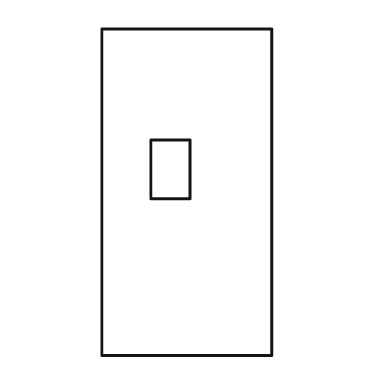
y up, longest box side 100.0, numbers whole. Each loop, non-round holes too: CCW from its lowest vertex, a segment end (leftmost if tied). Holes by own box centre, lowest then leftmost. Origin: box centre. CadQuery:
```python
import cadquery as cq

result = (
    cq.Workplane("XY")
    .moveTo(-26.0, -50.0)
    .lineTo(26.0, -50.0)
    .lineTo(26.0, 50.0)
    .lineTo(-26.0, 50.0)
    .close()
    .moveTo(-11.0, -2.0)
    .lineTo(1.0, -2.0)
    .lineTo(1.0, 16.0)
    .lineTo(-11.0, 16.0)
    .close()
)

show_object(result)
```